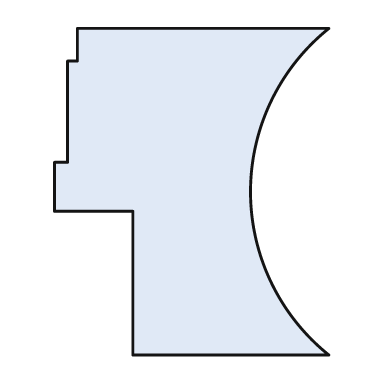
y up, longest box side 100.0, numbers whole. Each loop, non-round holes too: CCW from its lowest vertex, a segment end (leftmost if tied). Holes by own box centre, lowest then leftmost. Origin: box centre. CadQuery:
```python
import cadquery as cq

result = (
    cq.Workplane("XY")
    .moveTo(-18.0, -50.0)
    .lineTo(42.0, -50.0)
    .threePointArc((18.0, 0.0), (42.0, 50.0))
    .lineTo(-35.0, 50.0)
    .lineTo(-35.0, 40.0)
    .lineTo(-38.0, 40.0)
    .lineTo(-38.0, 9.0)
    .lineTo(-42.0, 9.0)
    .lineTo(-42.0, -6.0)
    .lineTo(-18.0, -6.0)
    .close()
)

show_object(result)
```